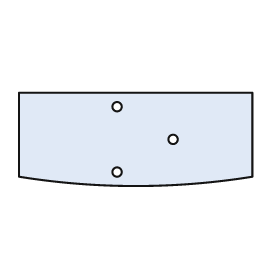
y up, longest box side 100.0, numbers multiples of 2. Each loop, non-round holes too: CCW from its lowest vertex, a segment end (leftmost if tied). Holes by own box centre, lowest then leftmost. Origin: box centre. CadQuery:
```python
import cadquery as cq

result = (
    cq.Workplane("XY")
    .moveTo(-50.0, -16.0)
    .threePointArc((0.0, -20.0), (50.0, -16.0))
    .lineTo(50.0, 20.0)
    .lineTo(-50.0, 20.0)
    .close()
    .moveTo(-8.0, -14.0)
    .circle(2.0)
    .moveTo(16.0, 0.0)
    .circle(2.0)
    .moveTo(-8.0, 14.0)
    .circle(2.0)
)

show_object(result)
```